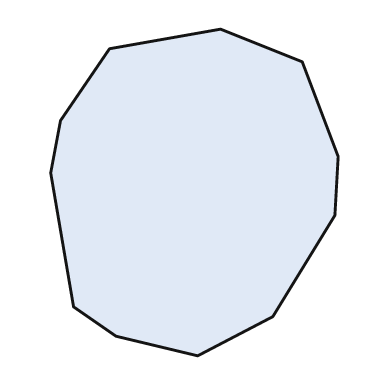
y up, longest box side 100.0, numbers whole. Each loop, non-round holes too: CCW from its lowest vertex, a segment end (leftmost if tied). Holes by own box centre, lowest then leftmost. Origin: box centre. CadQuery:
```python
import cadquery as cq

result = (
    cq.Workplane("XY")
    .moveTo(1.0, -50.0)
    .lineTo(24.0, -38.0)
    .lineTo(43.0, -7.0)
    .lineTo(44.0, 11.0)
    .lineTo(33.0, 40.0)
    .lineTo(8.0, 50.0)
    .lineTo(-26.0, 44.0)
    .lineTo(-41.0, 22.0)
    .lineTo(-44.0, 6.0)
    .lineTo(-37.0, -35.0)
    .lineTo(-24.0, -44.0)
    .close()
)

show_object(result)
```